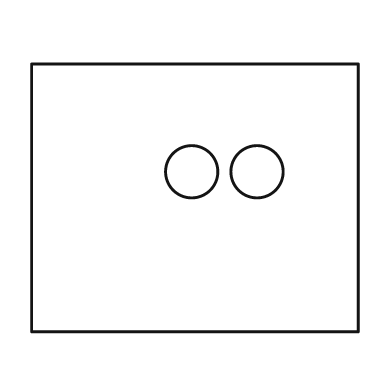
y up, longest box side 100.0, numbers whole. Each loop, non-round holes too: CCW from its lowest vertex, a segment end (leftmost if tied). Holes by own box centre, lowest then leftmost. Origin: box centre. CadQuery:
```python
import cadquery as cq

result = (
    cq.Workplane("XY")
    .moveTo(-50.0, -41.0)
    .lineTo(50.0, -41.0)
    .lineTo(50.0, 41.0)
    .lineTo(-50.0, 41.0)
    .close()
    .moveTo(-1.0, 8.0)
    .circle(8.0)
    .moveTo(19.0, 8.0)
    .circle(8.0)
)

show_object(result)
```